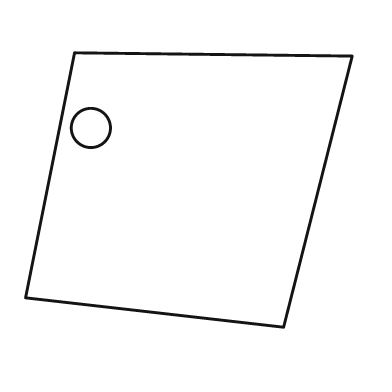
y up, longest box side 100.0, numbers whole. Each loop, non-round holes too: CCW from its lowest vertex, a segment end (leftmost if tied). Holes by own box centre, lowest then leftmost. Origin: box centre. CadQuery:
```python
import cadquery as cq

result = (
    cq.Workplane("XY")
    .moveTo(29.0, -42.0)
    .lineTo(50.0, 41.0)
    .lineTo(-35.0, 42.0)
    .lineTo(-50.0, -33.0)
    .close()
    .moveTo(-30.0, 19.0)
    .circle(6.0)
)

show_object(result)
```